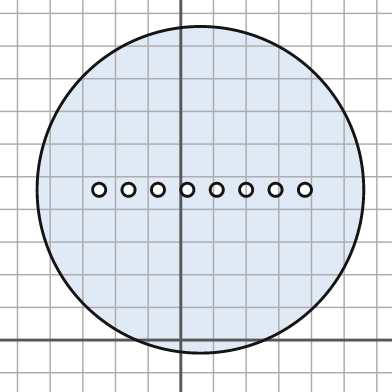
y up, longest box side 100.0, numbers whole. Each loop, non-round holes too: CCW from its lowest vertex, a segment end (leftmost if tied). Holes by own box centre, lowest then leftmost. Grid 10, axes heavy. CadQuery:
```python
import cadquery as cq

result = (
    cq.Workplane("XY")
    .moveTo(6.0, 46.0)
    .circle(50.0)
    .moveTo(-25.0, 46.0)
    .circle(2.0)
    .moveTo(-16.0, 46.0)
    .circle(2.0)
    .moveTo(-7.0, 46.0)
    .circle(2.0)
    .moveTo(2.0, 46.0)
    .circle(2.0)
    .moveTo(11.0, 46.0)
    .circle(2.0)
    .moveTo(20.0, 46.0)
    .circle(2.0)
    .moveTo(29.0, 46.0)
    .circle(2.0)
    .moveTo(38.0, 46.0)
    .circle(2.0)
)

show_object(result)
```